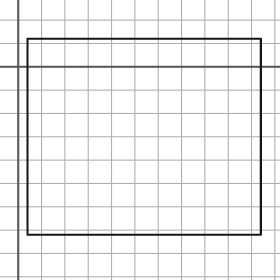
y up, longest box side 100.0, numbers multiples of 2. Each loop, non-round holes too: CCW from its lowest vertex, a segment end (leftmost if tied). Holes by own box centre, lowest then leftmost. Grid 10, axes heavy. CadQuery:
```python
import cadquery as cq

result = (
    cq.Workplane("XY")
    .moveTo(4.0, -72.0)
    .lineTo(104.0, -72.0)
    .lineTo(104.0, 12.0)
    .lineTo(4.0, 12.0)
    .close()
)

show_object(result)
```